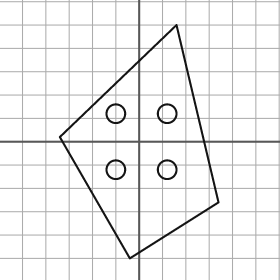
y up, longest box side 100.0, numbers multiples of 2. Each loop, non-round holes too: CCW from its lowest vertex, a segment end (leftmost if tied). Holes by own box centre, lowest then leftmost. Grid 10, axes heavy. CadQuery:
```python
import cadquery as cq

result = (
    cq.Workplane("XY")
    .moveTo(-4.0, -50.0)
    .lineTo(34.0, -26.0)
    .lineTo(16.0, 50.0)
    .lineTo(-34.0, 2.0)
    .close()
    .moveTo(-10.0, -12.0)
    .circle(4.0)
    .moveTo(12.0, -12.0)
    .circle(4.0)
    .moveTo(-10.0, 12.0)
    .circle(4.0)
    .moveTo(12.0, 12.0)
    .circle(4.0)
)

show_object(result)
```